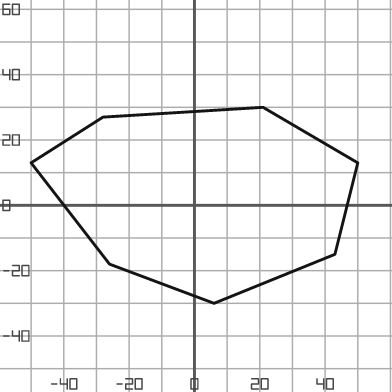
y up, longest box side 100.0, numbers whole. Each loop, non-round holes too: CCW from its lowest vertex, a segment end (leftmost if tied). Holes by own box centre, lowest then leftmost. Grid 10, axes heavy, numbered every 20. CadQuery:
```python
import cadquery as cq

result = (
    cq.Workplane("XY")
    .moveTo(6.0, -30.0)
    .lineTo(43.0, -15.0)
    .lineTo(50.0, 13.0)
    .lineTo(21.0, 30.0)
    .lineTo(-28.0, 27.0)
    .lineTo(-50.0, 13.0)
    .lineTo(-26.0, -18.0)
    .close()
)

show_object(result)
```